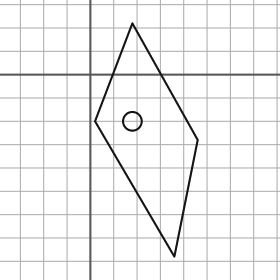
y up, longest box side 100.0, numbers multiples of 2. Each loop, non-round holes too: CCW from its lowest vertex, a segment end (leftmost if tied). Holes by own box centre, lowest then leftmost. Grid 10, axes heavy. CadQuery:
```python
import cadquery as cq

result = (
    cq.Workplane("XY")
    .moveTo(36.0, -78.0)
    .lineTo(46.0, -28.0)
    .lineTo(18.0, 22.0)
    .lineTo(2.0, -20.0)
    .close()
    .moveTo(18.0, -20.0)
    .circle(4.0)
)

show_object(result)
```